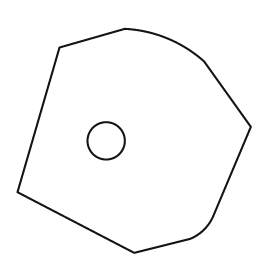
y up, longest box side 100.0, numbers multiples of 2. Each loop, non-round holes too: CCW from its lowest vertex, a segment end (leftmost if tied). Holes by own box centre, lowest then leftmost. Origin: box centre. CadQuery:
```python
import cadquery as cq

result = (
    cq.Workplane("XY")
    .moveTo(0.0, -48.0)
    .lineTo(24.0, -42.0)
    .threePointArc((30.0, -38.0), (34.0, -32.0))
    .lineTo(50.0, 6.0)
    .lineTo(30.0, 34.0)
    .threePointArc((14.0, 44.0), (-4.0, 48.0))
    .lineTo(-32.0, 40.0)
    .lineTo(-50.0, -22.0)
    .close()
    .moveTo(-12.0, 0.0)
    .circle(8.0)
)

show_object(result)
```